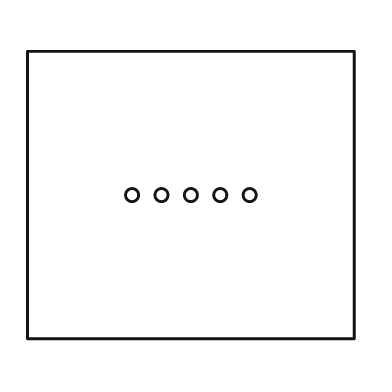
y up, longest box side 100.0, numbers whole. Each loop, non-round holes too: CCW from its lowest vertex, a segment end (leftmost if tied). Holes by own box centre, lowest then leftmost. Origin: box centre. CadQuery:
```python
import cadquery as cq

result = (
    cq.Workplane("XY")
    .moveTo(-50.0, -44.0)
    .lineTo(50.0, -44.0)
    .lineTo(50.0, 44.0)
    .lineTo(-50.0, 44.0)
    .close()
    .moveTo(-18.0, 0.0)
    .circle(2.0)
    .moveTo(-9.0, 0.0)
    .circle(2.0)
    .moveTo(0.0, 0.0)
    .circle(2.0)
    .moveTo(9.0, 0.0)
    .circle(2.0)
    .moveTo(18.0, 0.0)
    .circle(2.0)
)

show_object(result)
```